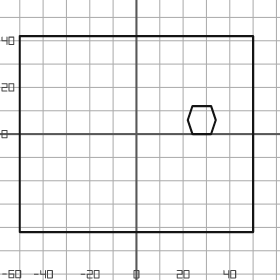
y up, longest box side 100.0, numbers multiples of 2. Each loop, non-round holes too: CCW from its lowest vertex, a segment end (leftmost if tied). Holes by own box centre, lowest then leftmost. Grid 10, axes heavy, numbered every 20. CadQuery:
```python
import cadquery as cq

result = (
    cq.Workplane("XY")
    .moveTo(-50.0, -42.0)
    .lineTo(50.0, -42.0)
    .lineTo(50.0, 42.0)
    .lineTo(-50.0, 42.0)
    .close()
    .moveTo(24.0, 0.0)
    .lineTo(32.0, 0.0)
    .lineTo(34.0, 6.0)
    .lineTo(32.0, 12.0)
    .lineTo(24.0, 12.0)
    .lineTo(22.0, 6.0)
    .close()
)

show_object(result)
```